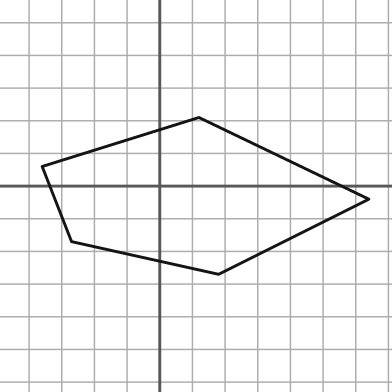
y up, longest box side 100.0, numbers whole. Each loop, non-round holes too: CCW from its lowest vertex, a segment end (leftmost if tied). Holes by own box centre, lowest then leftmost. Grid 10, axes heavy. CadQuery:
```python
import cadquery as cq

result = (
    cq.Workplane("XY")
    .moveTo(18.0, -27.0)
    .lineTo(64.0, -4.0)
    .lineTo(12.0, 21.0)
    .lineTo(-36.0, 6.0)
    .lineTo(-27.0, -17.0)
    .close()
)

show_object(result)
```